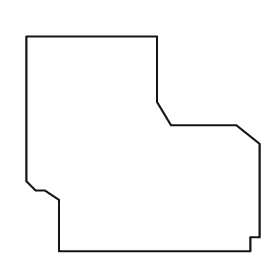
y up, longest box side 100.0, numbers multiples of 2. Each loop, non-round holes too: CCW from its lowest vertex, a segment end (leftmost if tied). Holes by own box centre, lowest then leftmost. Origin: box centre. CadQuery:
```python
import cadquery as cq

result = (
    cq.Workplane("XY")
    .moveTo(-36.0, -46.0)
    .lineTo(46.0, -46.0)
    .lineTo(46.0, -40.0)
    .lineTo(50.0, -40.0)
    .lineTo(50.0, 0.0)
    .lineTo(40.0, 8.0)
    .lineTo(12.0, 8.0)
    .lineTo(6.0, 18.0)
    .lineTo(6.0, 46.0)
    .lineTo(-50.0, 46.0)
    .lineTo(-50.0, -16.0)
    .lineTo(-46.0, -20.0)
    .lineTo(-42.0, -20.0)
    .lineTo(-36.0, -24.0)
    .close()
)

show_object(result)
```